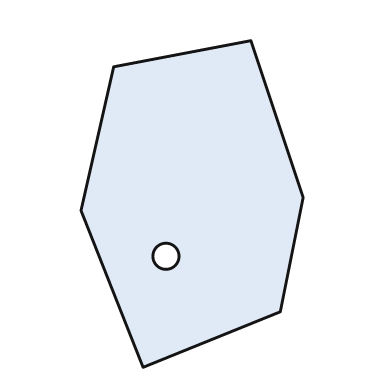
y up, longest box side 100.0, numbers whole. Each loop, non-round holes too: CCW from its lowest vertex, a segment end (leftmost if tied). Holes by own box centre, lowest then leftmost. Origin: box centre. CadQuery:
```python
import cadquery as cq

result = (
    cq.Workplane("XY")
    .moveTo(-15.0, -50.0)
    .lineTo(27.0, -33.0)
    .lineTo(34.0, 2.0)
    .lineTo(18.0, 50.0)
    .lineTo(-24.0, 42.0)
    .lineTo(-34.0, -2.0)
    .close()
    .moveTo(-8.0, -16.0)
    .circle(4.0)
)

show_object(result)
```